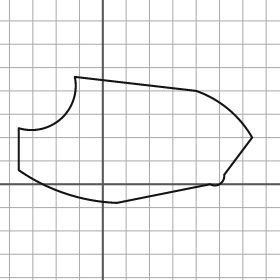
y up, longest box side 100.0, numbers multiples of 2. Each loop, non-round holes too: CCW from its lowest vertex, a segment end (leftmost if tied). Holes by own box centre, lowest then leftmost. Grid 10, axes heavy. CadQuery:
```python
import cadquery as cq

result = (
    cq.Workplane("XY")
    .moveTo(6.0, -8.0)
    .lineTo(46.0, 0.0)
    .threePointArc((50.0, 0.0), (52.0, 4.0))
    .lineTo(64.0, 20.0)
    .threePointArc((54.0, 32.0), (40.0, 40.0))
    .lineTo(-12.0, 46.0)
    .threePointArc((-18.0, 28.0), (-36.0, 24.0))
    .lineTo(-36.0, 6.0)
    .threePointArc((-16.0, -4.0), (6.0, -8.0))
    .close()
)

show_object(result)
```